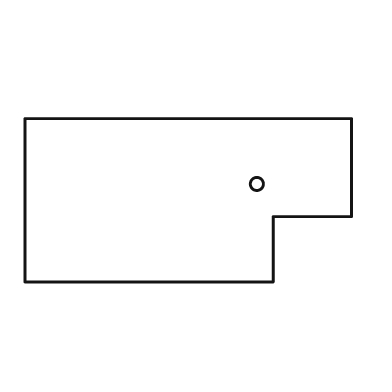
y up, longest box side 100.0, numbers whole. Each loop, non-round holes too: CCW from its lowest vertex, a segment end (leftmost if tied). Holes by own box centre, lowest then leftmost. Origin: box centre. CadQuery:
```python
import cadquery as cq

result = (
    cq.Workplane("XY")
    .moveTo(-50.0, -25.0)
    .lineTo(26.0, -25.0)
    .lineTo(26.0, -5.0)
    .lineTo(50.0, -5.0)
    .lineTo(50.0, 25.0)
    .lineTo(-50.0, 25.0)
    .close()
    .moveTo(21.0, 5.0)
    .circle(2.0)
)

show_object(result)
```